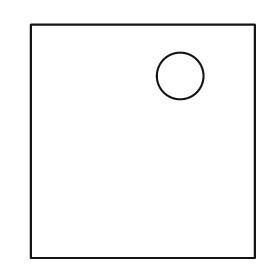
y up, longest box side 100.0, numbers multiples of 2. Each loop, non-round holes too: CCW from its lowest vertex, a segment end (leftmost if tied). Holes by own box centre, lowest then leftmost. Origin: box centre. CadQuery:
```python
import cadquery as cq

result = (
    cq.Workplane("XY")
    .moveTo(-48.0, -50.0)
    .lineTo(48.0, -50.0)
    .lineTo(48.0, 50.0)
    .lineTo(-48.0, 50.0)
    .close()
    .moveTo(16.0, 28.0)
    .circle(10.0)
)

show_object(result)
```